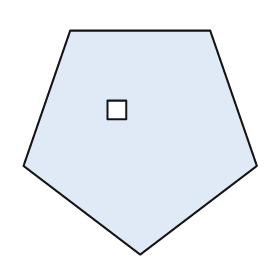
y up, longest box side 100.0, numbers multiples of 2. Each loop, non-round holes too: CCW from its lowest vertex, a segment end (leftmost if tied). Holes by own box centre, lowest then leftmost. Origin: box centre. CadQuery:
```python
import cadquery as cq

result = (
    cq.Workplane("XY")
    .moveTo(0.0, -48.0)
    .lineTo(50.0, -10.0)
    .lineTo(30.0, 48.0)
    .lineTo(-30.0, 48.0)
    .lineTo(-50.0, -10.0)
    .close()
    .moveTo(-14.0, 10.0)
    .lineTo(-6.0, 10.0)
    .lineTo(-6.0, 18.0)
    .lineTo(-14.0, 18.0)
    .close()
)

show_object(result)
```